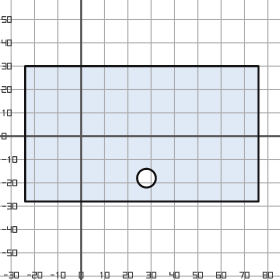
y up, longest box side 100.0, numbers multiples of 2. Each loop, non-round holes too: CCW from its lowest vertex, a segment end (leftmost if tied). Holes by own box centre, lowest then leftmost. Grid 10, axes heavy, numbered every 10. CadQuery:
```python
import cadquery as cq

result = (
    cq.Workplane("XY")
    .moveTo(-24.0, -28.0)
    .lineTo(76.0, -28.0)
    .lineTo(76.0, 30.0)
    .lineTo(-24.0, 30.0)
    .close()
    .moveTo(28.0, -18.0)
    .circle(4.0)
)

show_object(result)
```